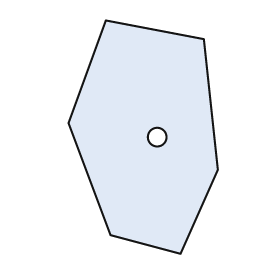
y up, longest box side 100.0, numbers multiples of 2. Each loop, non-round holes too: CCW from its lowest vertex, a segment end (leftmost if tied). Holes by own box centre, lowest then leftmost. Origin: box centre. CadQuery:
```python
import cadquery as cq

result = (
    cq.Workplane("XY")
    .moveTo(16.0, -50.0)
    .lineTo(32.0, -14.0)
    .lineTo(26.0, 42.0)
    .lineTo(-16.0, 50.0)
    .lineTo(-32.0, 6.0)
    .lineTo(-14.0, -42.0)
    .close()
    .moveTo(6.0, 0.0)
    .circle(4.0)
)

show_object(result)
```